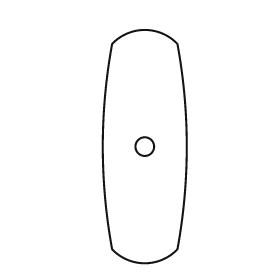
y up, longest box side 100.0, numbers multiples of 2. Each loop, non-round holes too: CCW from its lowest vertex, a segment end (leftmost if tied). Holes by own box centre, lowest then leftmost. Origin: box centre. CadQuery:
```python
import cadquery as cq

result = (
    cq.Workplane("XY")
    .moveTo(-14.0, -44.0)
    .threePointArc((0.0, -50.0), (14.0, -44.0))
    .threePointArc((18.0, 0.0), (14.0, 44.0))
    .threePointArc((0.0, 50.0), (-14.0, 44.0))
    .threePointArc((-18.0, 0.0), (-14.0, -44.0))
    .close()
    .moveTo(0.0, 0.0)
    .circle(4.0)
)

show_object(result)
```